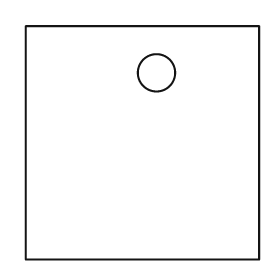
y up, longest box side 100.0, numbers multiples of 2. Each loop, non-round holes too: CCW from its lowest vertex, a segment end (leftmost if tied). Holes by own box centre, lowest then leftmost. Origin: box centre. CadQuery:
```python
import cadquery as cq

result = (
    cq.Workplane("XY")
    .moveTo(-50.0, -50.0)
    .lineTo(50.0, -50.0)
    .lineTo(50.0, 50.0)
    .lineTo(-50.0, 50.0)
    .close()
    .moveTo(6.0, 30.0)
    .circle(8.0)
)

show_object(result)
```